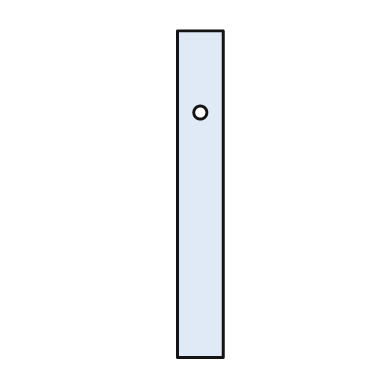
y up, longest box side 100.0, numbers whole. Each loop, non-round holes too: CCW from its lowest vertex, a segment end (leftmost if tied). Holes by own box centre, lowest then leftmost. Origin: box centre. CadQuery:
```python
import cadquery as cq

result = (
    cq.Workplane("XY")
    .moveTo(-7.0, -50.0)
    .lineTo(7.0, -50.0)
    .lineTo(7.0, 50.0)
    .lineTo(-7.0, 50.0)
    .close()
    .moveTo(0.0, 25.0)
    .circle(2.0)
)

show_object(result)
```